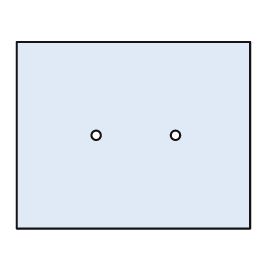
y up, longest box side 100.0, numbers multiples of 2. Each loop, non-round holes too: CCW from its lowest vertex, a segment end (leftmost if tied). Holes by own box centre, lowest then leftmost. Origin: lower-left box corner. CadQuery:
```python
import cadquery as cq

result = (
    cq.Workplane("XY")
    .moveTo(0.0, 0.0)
    .lineTo(100.0, 0.0)
    .lineTo(100.0, 80.0)
    .lineTo(0.0, 80.0)
    .close()
    .moveTo(34.0, 40.0)
    .circle(2.0)
    .moveTo(68.0, 40.0)
    .circle(2.0)
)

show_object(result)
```